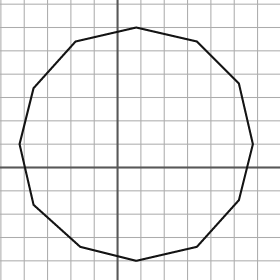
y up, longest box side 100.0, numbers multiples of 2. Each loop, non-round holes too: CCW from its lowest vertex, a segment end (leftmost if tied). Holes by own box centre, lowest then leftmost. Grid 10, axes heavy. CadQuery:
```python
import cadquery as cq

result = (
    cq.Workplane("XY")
    .moveTo(8.0, -40.0)
    .lineTo(34.0, -34.0)
    .lineTo(52.0, -14.0)
    .lineTo(58.0, 10.0)
    .lineTo(52.0, 36.0)
    .lineTo(34.0, 54.0)
    .lineTo(8.0, 60.0)
    .lineTo(-18.0, 54.0)
    .lineTo(-36.0, 34.0)
    .lineTo(-42.0, 10.0)
    .lineTo(-36.0, -16.0)
    .lineTo(-16.0, -34.0)
    .close()
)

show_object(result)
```